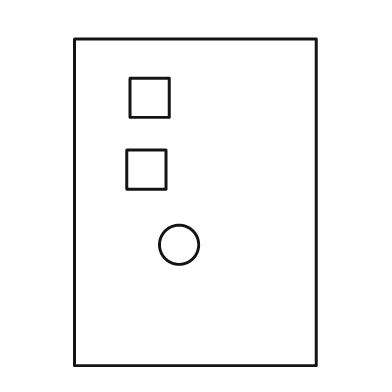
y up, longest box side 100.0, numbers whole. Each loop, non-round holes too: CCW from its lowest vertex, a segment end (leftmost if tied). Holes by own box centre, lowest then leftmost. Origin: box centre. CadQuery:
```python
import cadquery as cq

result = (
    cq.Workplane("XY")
    .moveTo(-37.0, -50.0)
    .lineTo(37.0, -50.0)
    .lineTo(37.0, 50.0)
    .lineTo(-37.0, 50.0)
    .close()
    .moveTo(-5.0, -13.0)
    .circle(6.0)
    .moveTo(-21.0, 4.0)
    .lineTo(-9.0, 4.0)
    .lineTo(-9.0, 16.0)
    .lineTo(-21.0, 16.0)
    .close()
    .moveTo(-20.0, 26.0)
    .lineTo(-8.0, 26.0)
    .lineTo(-8.0, 38.0)
    .lineTo(-20.0, 38.0)
    .close()
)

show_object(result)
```